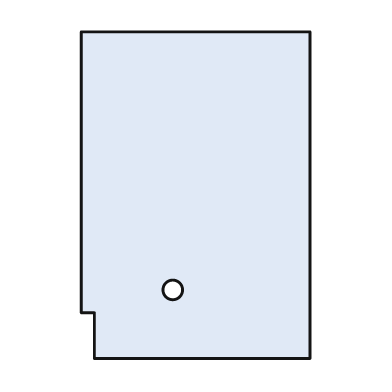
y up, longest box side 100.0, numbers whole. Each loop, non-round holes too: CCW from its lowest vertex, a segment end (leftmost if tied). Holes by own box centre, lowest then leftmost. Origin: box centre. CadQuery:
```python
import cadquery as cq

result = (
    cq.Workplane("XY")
    .moveTo(-31.0, -50.0)
    .lineTo(35.0, -50.0)
    .lineTo(35.0, 50.0)
    .lineTo(-35.0, 50.0)
    .lineTo(-35.0, -36.0)
    .lineTo(-31.0, -36.0)
    .close()
    .moveTo(-7.0, -29.0)
    .circle(3.0)
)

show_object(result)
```